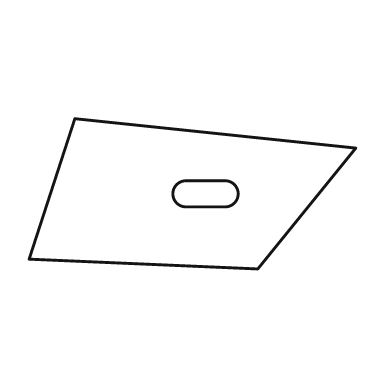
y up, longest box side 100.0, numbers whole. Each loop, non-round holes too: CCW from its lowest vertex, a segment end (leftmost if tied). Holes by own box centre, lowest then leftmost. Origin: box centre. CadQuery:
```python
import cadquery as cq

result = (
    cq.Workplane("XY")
    .moveTo(20.0, -23.0)
    .lineTo(50.0, 14.0)
    .lineTo(-36.0, 23.0)
    .lineTo(-50.0, -20.0)
    .close()
    .moveTo(-2.0, -4.0)
    .lineTo(10.0, -4.0)
    .threePointArc((14.0, 0.0), (10.0, 4.0))
    .lineTo(-2.0, 4.0)
    .threePointArc((-6.0, 0.0), (-2.0, -4.0))
    .close()
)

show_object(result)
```